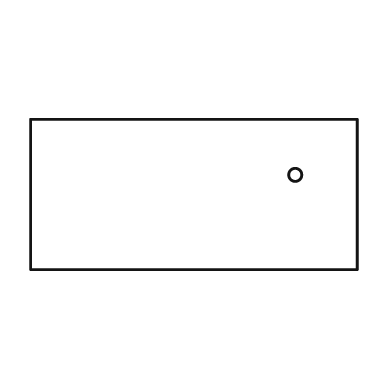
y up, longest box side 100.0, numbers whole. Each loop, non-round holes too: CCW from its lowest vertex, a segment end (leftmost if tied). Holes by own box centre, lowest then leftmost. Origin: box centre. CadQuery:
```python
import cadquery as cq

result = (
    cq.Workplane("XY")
    .moveTo(-50.0, -23.0)
    .lineTo(50.0, -23.0)
    .lineTo(50.0, 23.0)
    .lineTo(-50.0, 23.0)
    .close()
    .moveTo(31.0, 6.0)
    .circle(2.0)
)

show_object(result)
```